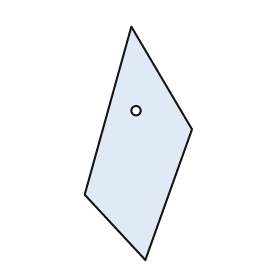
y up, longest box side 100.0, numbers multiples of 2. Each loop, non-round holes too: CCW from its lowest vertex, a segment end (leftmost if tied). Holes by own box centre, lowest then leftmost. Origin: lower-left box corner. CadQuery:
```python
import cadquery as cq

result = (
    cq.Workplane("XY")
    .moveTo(26.0, 0.0)
    .lineTo(46.0, 56.0)
    .lineTo(20.0, 100.0)
    .lineTo(0.0, 28.0)
    .close()
    .moveTo(22.0, 64.0)
    .circle(2.0)
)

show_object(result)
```